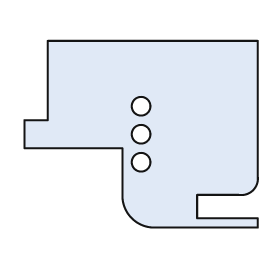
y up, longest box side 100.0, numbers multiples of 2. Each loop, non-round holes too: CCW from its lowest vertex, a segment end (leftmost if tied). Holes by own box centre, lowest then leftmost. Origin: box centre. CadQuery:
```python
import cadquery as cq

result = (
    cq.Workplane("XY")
    .moveTo(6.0, -40.0)
    .lineTo(50.0, -40.0)
    .lineTo(50.0, -36.0)
    .lineTo(24.0, -36.0)
    .lineTo(24.0, -26.0)
    .lineTo(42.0, -26.0)
    .threePointArc((48.0, -24.0), (50.0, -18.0))
    .lineTo(50.0, 40.0)
    .lineTo(-40.0, 40.0)
    .lineTo(-40.0, 6.0)
    .lineTo(-50.0, 6.0)
    .lineTo(-50.0, -6.0)
    .lineTo(-8.0, -6.0)
    .lineTo(-8.0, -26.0)
    .threePointArc((-4.0, -36.0), (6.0, -40.0))
    .close()
    .moveTo(0.0, -12.0)
    .circle(4.0)
    .moveTo(0.0, 0.0)
    .circle(4.0)
    .moveTo(0.0, 12.0)
    .circle(4.0)
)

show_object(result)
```